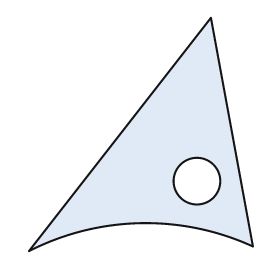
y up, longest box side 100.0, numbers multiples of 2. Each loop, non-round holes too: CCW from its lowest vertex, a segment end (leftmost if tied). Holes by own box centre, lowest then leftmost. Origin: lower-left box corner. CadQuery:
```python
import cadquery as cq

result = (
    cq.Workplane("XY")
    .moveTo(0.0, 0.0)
    .threePointArc((48.0, 12.0), (96.0, 2.0))
    .lineTo(78.0, 100.0)
    .close()
    .moveTo(72.0, 30.0)
    .circle(10.0)
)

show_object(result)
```